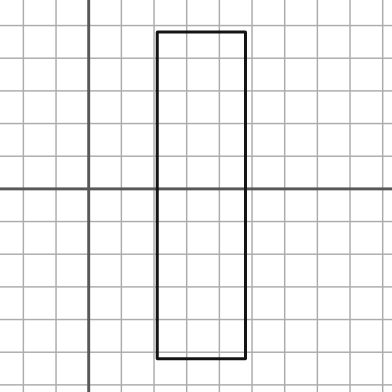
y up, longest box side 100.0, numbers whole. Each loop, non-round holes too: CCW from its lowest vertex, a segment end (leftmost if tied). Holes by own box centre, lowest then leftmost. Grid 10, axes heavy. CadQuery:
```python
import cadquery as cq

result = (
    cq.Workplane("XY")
    .moveTo(21.0, -52.0)
    .lineTo(48.0, -52.0)
    .lineTo(48.0, 48.0)
    .lineTo(21.0, 48.0)
    .close()
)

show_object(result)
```